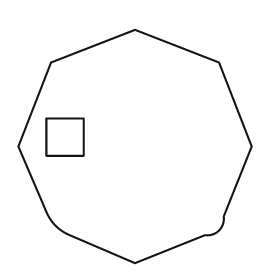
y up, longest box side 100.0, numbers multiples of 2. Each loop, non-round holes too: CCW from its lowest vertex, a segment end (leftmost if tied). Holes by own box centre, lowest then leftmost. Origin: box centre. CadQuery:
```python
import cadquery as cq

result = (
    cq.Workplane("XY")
    .moveTo(0.0, -50.0)
    .lineTo(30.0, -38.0)
    .threePointArc((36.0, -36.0), (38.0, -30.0))
    .lineTo(50.0, 0.0)
    .lineTo(36.0, 36.0)
    .lineTo(0.0, 50.0)
    .lineTo(-36.0, 36.0)
    .lineTo(-50.0, 0.0)
    .lineTo(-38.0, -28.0)
    .threePointArc((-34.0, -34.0), (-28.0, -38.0))
    .close()
    .moveTo(-38.0, -4.0)
    .lineTo(-22.0, -4.0)
    .lineTo(-22.0, 12.0)
    .lineTo(-38.0, 12.0)
    .close()
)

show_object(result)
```